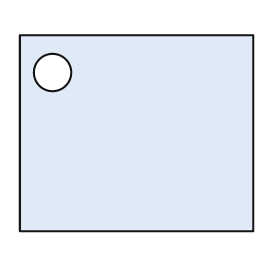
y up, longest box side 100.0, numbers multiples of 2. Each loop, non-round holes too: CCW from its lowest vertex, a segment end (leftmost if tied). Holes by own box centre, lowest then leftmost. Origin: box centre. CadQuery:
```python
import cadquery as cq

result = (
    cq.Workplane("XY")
    .moveTo(-50.0, -42.0)
    .lineTo(50.0, -42.0)
    .lineTo(50.0, 42.0)
    .lineTo(-50.0, 42.0)
    .close()
    .moveTo(-36.0, 26.0)
    .circle(8.0)
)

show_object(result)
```